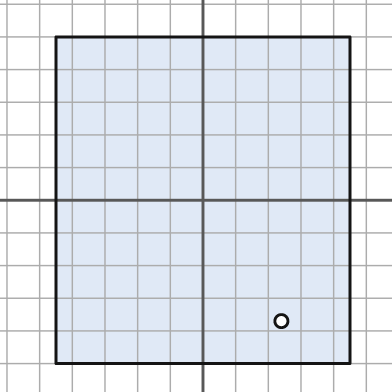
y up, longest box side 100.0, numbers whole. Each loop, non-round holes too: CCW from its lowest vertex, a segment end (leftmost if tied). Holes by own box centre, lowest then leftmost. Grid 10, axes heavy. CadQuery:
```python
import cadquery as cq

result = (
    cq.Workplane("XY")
    .moveTo(-45.0, -50.0)
    .lineTo(45.0, -50.0)
    .lineTo(45.0, 50.0)
    .lineTo(-45.0, 50.0)
    .close()
    .moveTo(24.0, -37.0)
    .circle(2.0)
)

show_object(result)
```